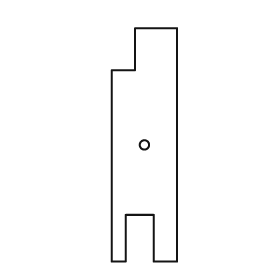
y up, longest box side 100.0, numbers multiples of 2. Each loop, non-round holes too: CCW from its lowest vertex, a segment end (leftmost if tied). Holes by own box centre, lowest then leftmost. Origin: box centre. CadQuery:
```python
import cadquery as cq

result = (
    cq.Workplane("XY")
    .moveTo(-14.0, -50.0)
    .lineTo(-8.0, -50.0)
    .lineTo(-8.0, -30.0)
    .lineTo(4.0, -30.0)
    .lineTo(4.0, -50.0)
    .lineTo(14.0, -50.0)
    .lineTo(14.0, 50.0)
    .lineTo(-4.0, 50.0)
    .lineTo(-4.0, 32.0)
    .lineTo(-14.0, 32.0)
    .close()
    .moveTo(0.0, 0.0)
    .circle(2.0)
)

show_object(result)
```